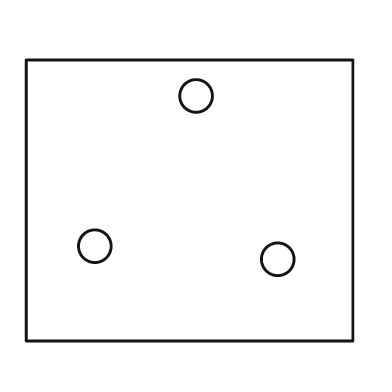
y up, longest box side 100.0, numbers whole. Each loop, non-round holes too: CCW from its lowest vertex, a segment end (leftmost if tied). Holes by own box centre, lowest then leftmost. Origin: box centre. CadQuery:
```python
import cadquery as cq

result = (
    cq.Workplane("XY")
    .moveTo(-50.0, -43.0)
    .lineTo(50.0, -43.0)
    .lineTo(50.0, 43.0)
    .lineTo(-50.0, 43.0)
    .close()
    .moveTo(27.0, -18.0)
    .circle(5.0)
    .moveTo(-29.0, -14.0)
    .circle(5.0)
    .moveTo(2.0, 32.0)
    .circle(5.0)
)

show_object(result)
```